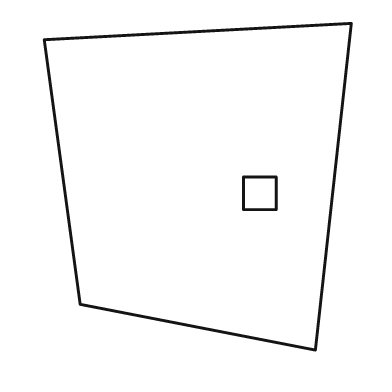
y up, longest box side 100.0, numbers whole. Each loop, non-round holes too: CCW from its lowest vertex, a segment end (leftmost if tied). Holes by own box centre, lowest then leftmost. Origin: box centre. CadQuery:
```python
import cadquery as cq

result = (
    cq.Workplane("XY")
    .moveTo(36.0, -50.0)
    .lineTo(47.0, 50.0)
    .lineTo(-47.0, 45.0)
    .lineTo(-36.0, -36.0)
    .close()
    .moveTo(14.0, -7.0)
    .lineTo(24.0, -7.0)
    .lineTo(24.0, 3.0)
    .lineTo(14.0, 3.0)
    .close()
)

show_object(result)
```